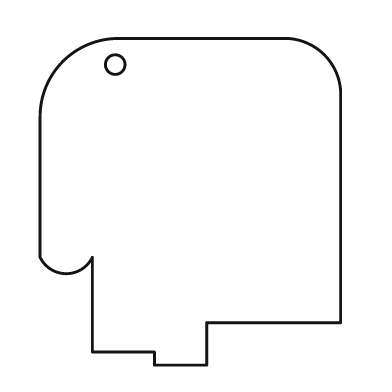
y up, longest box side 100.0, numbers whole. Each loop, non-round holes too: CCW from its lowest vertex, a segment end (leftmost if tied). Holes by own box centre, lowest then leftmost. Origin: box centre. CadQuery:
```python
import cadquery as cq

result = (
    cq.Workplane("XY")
    .moveTo(-11.0, -50.0)
    .lineTo(5.0, -50.0)
    .lineTo(5.0, -37.0)
    .lineTo(46.0, -37.0)
    .lineTo(46.0, 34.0)
    .threePointArc((41.0, 45.0), (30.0, 50.0))
    .lineTo(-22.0, 50.0)
    .threePointArc((-39.0, 43.0), (-46.0, 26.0))
    .lineTo(-46.0, -17.0)
    .threePointArc((-38.0, -22.0), (-30.0, -17.0))
    .lineTo(-30.0, -46.0)
    .lineTo(-11.0, -46.0)
    .close()
    .moveTo(-23.0, 42.0)
    .circle(3.0)
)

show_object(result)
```